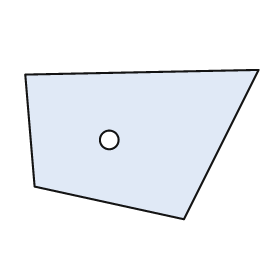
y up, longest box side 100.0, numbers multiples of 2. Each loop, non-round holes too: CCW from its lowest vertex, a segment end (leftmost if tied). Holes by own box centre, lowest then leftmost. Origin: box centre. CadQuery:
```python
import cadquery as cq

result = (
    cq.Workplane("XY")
    .moveTo(18.0, -32.0)
    .lineTo(50.0, 32.0)
    .lineTo(-50.0, 30.0)
    .lineTo(-46.0, -18.0)
    .close()
    .moveTo(-14.0, 2.0)
    .circle(4.0)
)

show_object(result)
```